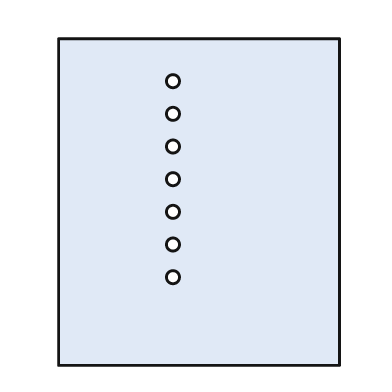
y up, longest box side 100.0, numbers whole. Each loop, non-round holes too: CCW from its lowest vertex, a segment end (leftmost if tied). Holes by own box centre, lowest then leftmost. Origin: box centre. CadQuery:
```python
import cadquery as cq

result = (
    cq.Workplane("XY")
    .moveTo(-43.0, -50.0)
    .lineTo(43.0, -50.0)
    .lineTo(43.0, 50.0)
    .lineTo(-43.0, 50.0)
    .close()
    .moveTo(-8.0, -23.0)
    .circle(2.0)
    .moveTo(-8.0, -13.0)
    .circle(2.0)
    .moveTo(-8.0, -3.0)
    .circle(2.0)
    .moveTo(-8.0, 7.0)
    .circle(2.0)
    .moveTo(-8.0, 17.0)
    .circle(2.0)
    .moveTo(-8.0, 27.0)
    .circle(2.0)
    .moveTo(-8.0, 37.0)
    .circle(2.0)
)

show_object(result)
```